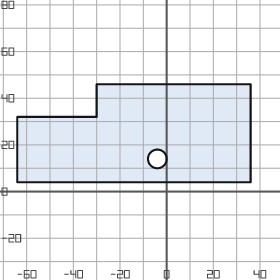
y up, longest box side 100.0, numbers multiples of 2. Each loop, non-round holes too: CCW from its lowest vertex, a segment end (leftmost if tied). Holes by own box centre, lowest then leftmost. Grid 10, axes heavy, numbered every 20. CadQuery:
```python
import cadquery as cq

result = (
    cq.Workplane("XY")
    .moveTo(-64.0, 4.0)
    .lineTo(36.0, 4.0)
    .lineTo(36.0, 46.0)
    .lineTo(-30.0, 46.0)
    .lineTo(-30.0, 32.0)
    .lineTo(-64.0, 32.0)
    .close()
    .moveTo(-4.0, 14.0)
    .circle(4.0)
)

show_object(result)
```